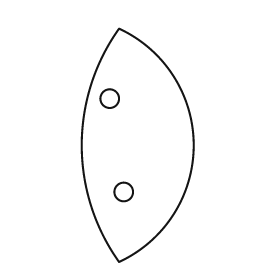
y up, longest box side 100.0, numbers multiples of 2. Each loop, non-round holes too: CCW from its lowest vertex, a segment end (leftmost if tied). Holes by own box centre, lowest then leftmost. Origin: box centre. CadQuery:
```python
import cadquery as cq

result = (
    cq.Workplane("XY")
    .moveTo(-8.0, -50.0)
    .threePointArc((24.0, 0.0), (-8.0, 50.0))
    .threePointArc((-24.0, 0.0), (-8.0, -50.0))
    .close()
    .moveTo(-6.0, -20.0)
    .circle(4.0)
    .moveTo(-12.0, 20.0)
    .circle(4.0)
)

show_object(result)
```